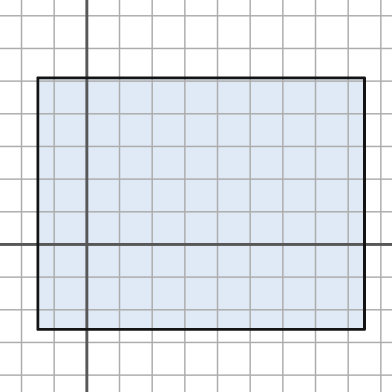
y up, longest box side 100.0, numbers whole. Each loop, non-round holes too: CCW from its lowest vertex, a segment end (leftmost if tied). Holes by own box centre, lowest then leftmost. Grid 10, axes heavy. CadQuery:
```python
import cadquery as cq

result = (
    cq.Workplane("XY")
    .moveTo(-15.0, -26.0)
    .lineTo(85.0, -26.0)
    .lineTo(85.0, 51.0)
    .lineTo(-15.0, 51.0)
    .close()
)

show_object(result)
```